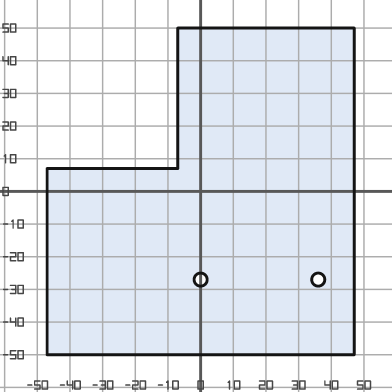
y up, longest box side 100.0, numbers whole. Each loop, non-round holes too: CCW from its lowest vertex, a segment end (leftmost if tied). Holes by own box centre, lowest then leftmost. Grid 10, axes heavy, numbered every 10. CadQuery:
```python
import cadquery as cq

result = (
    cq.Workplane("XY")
    .moveTo(-47.0, -50.0)
    .lineTo(47.0, -50.0)
    .lineTo(47.0, 50.0)
    .lineTo(-7.0, 50.0)
    .lineTo(-7.0, 7.0)
    .lineTo(-47.0, 7.0)
    .close()
    .moveTo(0.0, -27.0)
    .circle(2.0)
    .moveTo(36.0, -27.0)
    .circle(2.0)
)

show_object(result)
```